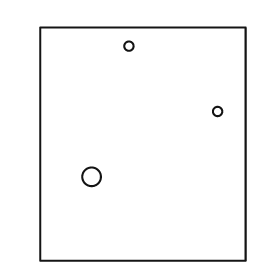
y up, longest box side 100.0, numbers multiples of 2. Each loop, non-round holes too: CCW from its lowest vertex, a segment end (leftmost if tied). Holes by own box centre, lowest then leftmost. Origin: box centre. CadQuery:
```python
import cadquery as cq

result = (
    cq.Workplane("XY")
    .moveTo(-44.0, -50.0)
    .lineTo(44.0, -50.0)
    .lineTo(44.0, 50.0)
    .lineTo(-44.0, 50.0)
    .close()
    .moveTo(-22.0, -14.0)
    .circle(4.0)
    .moveTo(32.0, 14.0)
    .circle(2.0)
    .moveTo(-6.0, 42.0)
    .circle(2.0)
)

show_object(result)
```